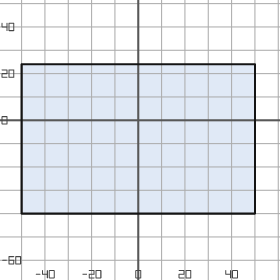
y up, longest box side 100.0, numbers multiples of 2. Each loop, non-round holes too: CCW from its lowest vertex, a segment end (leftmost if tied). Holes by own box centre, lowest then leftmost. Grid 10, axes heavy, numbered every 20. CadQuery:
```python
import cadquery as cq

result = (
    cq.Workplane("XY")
    .moveTo(-50.0, -40.0)
    .lineTo(50.0, -40.0)
    .lineTo(50.0, 24.0)
    .lineTo(-50.0, 24.0)
    .close()
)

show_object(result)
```